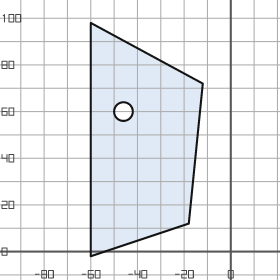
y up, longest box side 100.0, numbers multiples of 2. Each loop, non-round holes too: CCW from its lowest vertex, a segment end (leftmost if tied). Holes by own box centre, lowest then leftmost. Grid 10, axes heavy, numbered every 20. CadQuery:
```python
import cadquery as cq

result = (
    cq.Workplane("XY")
    .moveTo(-60.0, -2.0)
    .lineTo(-18.0, 12.0)
    .lineTo(-12.0, 72.0)
    .lineTo(-60.0, 98.0)
    .close()
    .moveTo(-46.0, 60.0)
    .circle(4.0)
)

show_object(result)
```